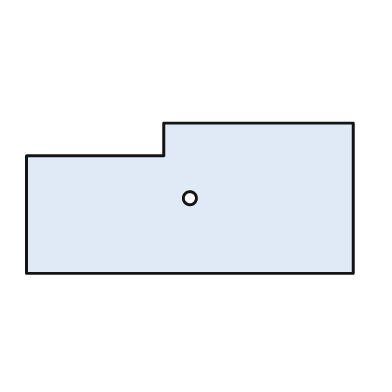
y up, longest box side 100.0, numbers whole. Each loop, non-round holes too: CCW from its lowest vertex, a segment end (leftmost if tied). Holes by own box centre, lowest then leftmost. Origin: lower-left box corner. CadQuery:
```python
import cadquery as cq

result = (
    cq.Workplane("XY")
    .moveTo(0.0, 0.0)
    .lineTo(100.0, 0.0)
    .lineTo(100.0, 46.0)
    .lineTo(42.0, 46.0)
    .lineTo(42.0, 36.0)
    .lineTo(0.0, 36.0)
    .close()
    .moveTo(50.0, 23.0)
    .circle(2.0)
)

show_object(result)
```